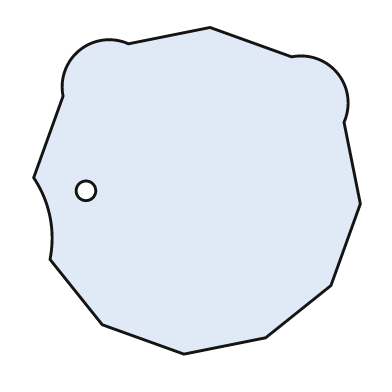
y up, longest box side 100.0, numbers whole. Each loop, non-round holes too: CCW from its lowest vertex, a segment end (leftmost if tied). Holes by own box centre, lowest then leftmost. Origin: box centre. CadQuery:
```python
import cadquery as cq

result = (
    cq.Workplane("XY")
    .moveTo(-4.0, -50.0)
    .lineTo(21.0, -45.0)
    .lineTo(41.0, -29.0)
    .lineTo(50.0, -4.0)
    .lineTo(45.0, 21.0)
    .threePointArc((43.0, 36.0), (29.0, 41.0))
    .lineTo(4.0, 50.0)
    .lineTo(-21.0, 45.0)
    .threePointArc((-36.0, 43.0), (-41.0, 29.0))
    .lineTo(-50.0, 4.0)
    .threePointArc((-45.0, -8.0), (-45.0, -21.0))
    .lineTo(-29.0, -41.0)
    .close()
    .moveTo(-34.0, 0.0)
    .circle(3.0)
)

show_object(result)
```